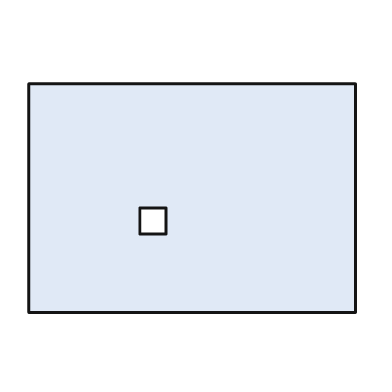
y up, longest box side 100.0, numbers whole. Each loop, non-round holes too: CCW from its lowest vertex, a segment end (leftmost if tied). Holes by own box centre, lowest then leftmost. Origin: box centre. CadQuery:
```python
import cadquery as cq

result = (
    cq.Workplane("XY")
    .moveTo(-50.0, -35.0)
    .lineTo(50.0, -35.0)
    .lineTo(50.0, 35.0)
    .lineTo(-50.0, 35.0)
    .close()
    .moveTo(-16.0, -11.0)
    .lineTo(-8.0, -11.0)
    .lineTo(-8.0, -3.0)
    .lineTo(-16.0, -3.0)
    .close()
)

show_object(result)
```